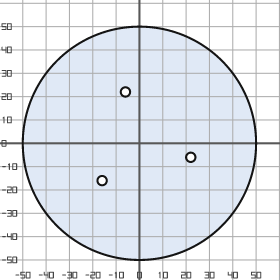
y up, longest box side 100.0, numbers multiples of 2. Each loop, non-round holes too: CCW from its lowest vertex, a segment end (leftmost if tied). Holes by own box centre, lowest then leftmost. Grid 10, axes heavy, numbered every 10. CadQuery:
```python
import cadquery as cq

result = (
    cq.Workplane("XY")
    .moveTo(0.0, 0.0)
    .circle(50.0)
    .moveTo(-16.0, -16.0)
    .circle(2.0)
    .moveTo(22.0, -6.0)
    .circle(2.0)
    .moveTo(-6.0, 22.0)
    .circle(2.0)
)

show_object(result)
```